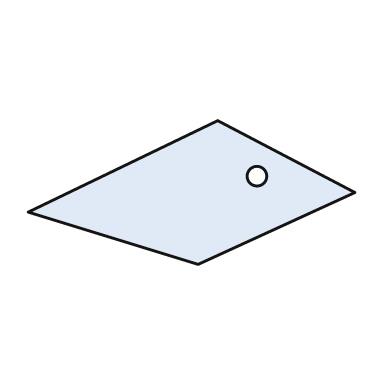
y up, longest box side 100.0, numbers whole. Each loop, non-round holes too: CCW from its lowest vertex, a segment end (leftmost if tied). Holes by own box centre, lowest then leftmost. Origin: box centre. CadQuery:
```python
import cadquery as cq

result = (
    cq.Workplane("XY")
    .moveTo(2.0, -22.0)
    .lineTo(50.0, 0.0)
    .lineTo(8.0, 22.0)
    .lineTo(-50.0, -6.0)
    .close()
    .moveTo(20.0, 5.0)
    .circle(3.0)
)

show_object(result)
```